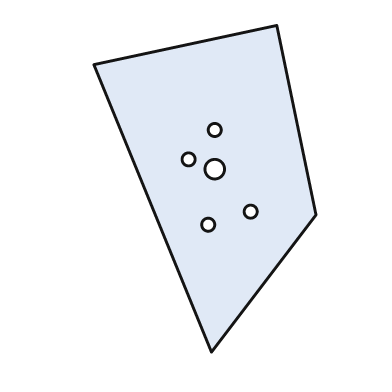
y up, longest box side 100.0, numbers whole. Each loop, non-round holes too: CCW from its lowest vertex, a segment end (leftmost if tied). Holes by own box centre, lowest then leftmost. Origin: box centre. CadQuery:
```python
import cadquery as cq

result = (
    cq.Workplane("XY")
    .moveTo(2.0, -50.0)
    .lineTo(34.0, -8.0)
    .lineTo(22.0, 50.0)
    .lineTo(-34.0, 38.0)
    .close()
    .moveTo(1.0, -11.0)
    .circle(2.0)
    .moveTo(14.0, -7.0)
    .circle(2.0)
    .moveTo(3.0, 6.0)
    .circle(3.0)
    .moveTo(-5.0, 9.0)
    .circle(2.0)
    .moveTo(3.0, 18.0)
    .circle(2.0)
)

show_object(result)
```